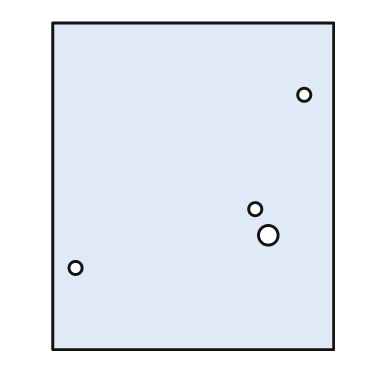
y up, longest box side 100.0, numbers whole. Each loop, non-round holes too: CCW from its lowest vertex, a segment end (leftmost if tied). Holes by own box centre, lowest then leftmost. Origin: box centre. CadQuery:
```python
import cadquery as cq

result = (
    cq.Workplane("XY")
    .moveTo(-43.0, -50.0)
    .lineTo(43.0, -50.0)
    .lineTo(43.0, 50.0)
    .lineTo(-43.0, 50.0)
    .close()
    .moveTo(-36.0, -25.0)
    .circle(2.0)
    .moveTo(23.0, -15.0)
    .circle(3.0)
    .moveTo(19.0, -7.0)
    .circle(2.0)
    .moveTo(34.0, 28.0)
    .circle(2.0)
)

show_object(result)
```